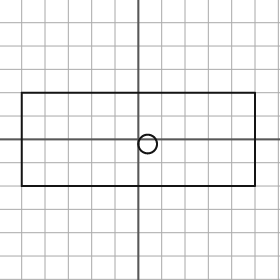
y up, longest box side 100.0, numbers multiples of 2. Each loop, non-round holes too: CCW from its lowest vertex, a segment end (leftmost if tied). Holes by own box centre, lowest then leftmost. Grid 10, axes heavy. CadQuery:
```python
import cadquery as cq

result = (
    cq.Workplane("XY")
    .moveTo(-50.0, -20.0)
    .lineTo(50.0, -20.0)
    .lineTo(50.0, 20.0)
    .lineTo(-50.0, 20.0)
    .close()
    .moveTo(4.0, -2.0)
    .circle(4.0)
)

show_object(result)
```